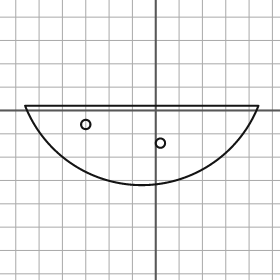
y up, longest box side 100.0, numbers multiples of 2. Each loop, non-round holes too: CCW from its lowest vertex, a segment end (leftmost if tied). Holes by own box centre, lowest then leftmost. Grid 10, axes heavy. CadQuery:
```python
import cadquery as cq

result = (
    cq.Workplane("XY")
    .moveTo(-56.0, 2.0)
    .threePointArc((-6.0, -32.0), (44.0, 2.0))
    .close()
    .moveTo(2.0, -14.0)
    .circle(2.0)
    .moveTo(-30.0, -6.0)
    .circle(2.0)
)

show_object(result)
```